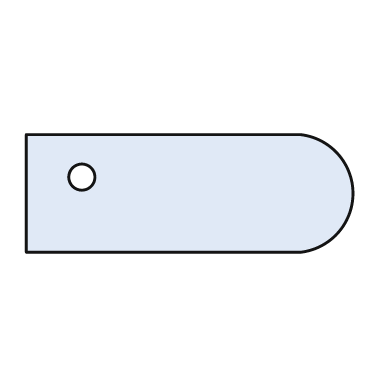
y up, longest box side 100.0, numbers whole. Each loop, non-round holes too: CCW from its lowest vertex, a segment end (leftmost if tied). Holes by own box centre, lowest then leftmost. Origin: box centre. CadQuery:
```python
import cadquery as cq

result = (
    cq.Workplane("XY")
    .moveTo(-50.0, -18.0)
    .lineTo(34.0, -18.0)
    .threePointArc((50.0, 0.0), (34.0, 18.0))
    .lineTo(-50.0, 18.0)
    .close()
    .moveTo(-33.0, 5.0)
    .circle(4.0)
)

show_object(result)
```